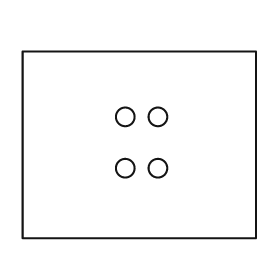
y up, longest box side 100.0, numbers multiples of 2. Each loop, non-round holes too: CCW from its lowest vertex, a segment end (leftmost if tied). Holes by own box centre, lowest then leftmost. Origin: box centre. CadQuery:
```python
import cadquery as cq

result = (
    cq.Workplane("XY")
    .moveTo(-50.0, -40.0)
    .lineTo(50.0, -40.0)
    .lineTo(50.0, 40.0)
    .lineTo(-50.0, 40.0)
    .close()
    .moveTo(-6.0, -10.0)
    .circle(4.0)
    .moveTo(8.0, -10.0)
    .circle(4.0)
    .moveTo(-6.0, 12.0)
    .circle(4.0)
    .moveTo(8.0, 12.0)
    .circle(4.0)
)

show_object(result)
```